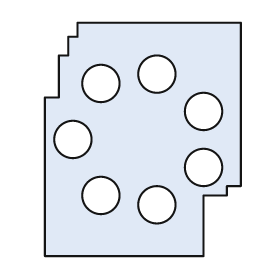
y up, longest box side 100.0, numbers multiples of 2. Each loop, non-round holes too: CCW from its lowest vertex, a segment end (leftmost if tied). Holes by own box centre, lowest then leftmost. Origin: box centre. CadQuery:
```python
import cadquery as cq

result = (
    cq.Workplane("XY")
    .moveTo(-42.0, -50.0)
    .lineTo(26.0, -50.0)
    .lineTo(26.0, -24.0)
    .lineTo(36.0, -24.0)
    .lineTo(36.0, -20.0)
    .lineTo(42.0, -20.0)
    .lineTo(42.0, 50.0)
    .lineTo(-28.0, 50.0)
    .lineTo(-28.0, 44.0)
    .lineTo(-32.0, 44.0)
    .lineTo(-32.0, 36.0)
    .lineTo(-36.0, 36.0)
    .lineTo(-36.0, 18.0)
    .lineTo(-42.0, 18.0)
    .close()
    .moveTo(6.0, -28.0)
    .circle(8.0)
    .moveTo(-18.0, -24.0)
    .circle(8.0)
    .moveTo(26.0, -12.0)
    .circle(8.0)
    .moveTo(-30.0, 0.0)
    .circle(8.0)
    .moveTo(26.0, 12.0)
    .circle(8.0)
    .moveTo(-18.0, 24.0)
    .circle(8.0)
    .moveTo(6.0, 28.0)
    .circle(8.0)
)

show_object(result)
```